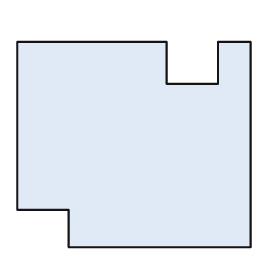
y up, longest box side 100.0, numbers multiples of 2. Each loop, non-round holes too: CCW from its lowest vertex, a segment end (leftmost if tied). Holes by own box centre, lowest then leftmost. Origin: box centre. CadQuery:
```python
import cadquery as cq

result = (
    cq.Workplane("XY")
    .moveTo(-28.0, -44.0)
    .lineTo(50.0, -44.0)
    .lineTo(50.0, 44.0)
    .lineTo(36.0, 44.0)
    .lineTo(36.0, 26.0)
    .lineTo(14.0, 26.0)
    .lineTo(14.0, 44.0)
    .lineTo(-50.0, 44.0)
    .lineTo(-50.0, -28.0)
    .lineTo(-28.0, -28.0)
    .close()
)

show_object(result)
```